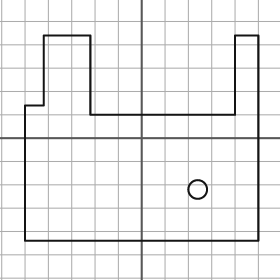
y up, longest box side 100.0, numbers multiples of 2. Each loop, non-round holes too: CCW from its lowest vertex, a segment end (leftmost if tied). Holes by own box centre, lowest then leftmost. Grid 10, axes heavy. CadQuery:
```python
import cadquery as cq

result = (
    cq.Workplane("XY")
    .moveTo(-50.0, -44.0)
    .lineTo(50.0, -44.0)
    .lineTo(50.0, 44.0)
    .lineTo(40.0, 44.0)
    .lineTo(40.0, 10.0)
    .lineTo(-22.0, 10.0)
    .lineTo(-22.0, 44.0)
    .lineTo(-42.0, 44.0)
    .lineTo(-42.0, 14.0)
    .lineTo(-50.0, 14.0)
    .close()
    .moveTo(24.0, -22.0)
    .circle(4.0)
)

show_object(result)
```